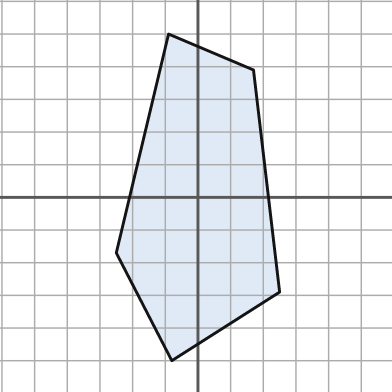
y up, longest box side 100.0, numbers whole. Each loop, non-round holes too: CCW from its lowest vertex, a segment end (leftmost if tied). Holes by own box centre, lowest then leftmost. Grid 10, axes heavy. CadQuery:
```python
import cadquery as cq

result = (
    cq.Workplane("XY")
    .moveTo(-8.0, -50.0)
    .lineTo(25.0, -29.0)
    .lineTo(17.0, 39.0)
    .lineTo(-9.0, 50.0)
    .lineTo(-25.0, -17.0)
    .close()
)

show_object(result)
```